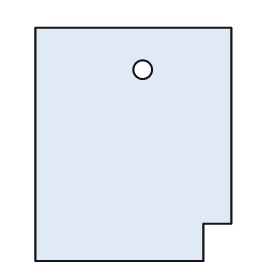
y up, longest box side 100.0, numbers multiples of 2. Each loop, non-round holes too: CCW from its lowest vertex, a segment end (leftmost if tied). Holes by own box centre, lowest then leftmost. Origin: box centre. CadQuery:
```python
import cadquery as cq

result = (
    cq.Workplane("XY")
    .moveTo(-42.0, -50.0)
    .lineTo(30.0, -50.0)
    .lineTo(30.0, -34.0)
    .lineTo(42.0, -34.0)
    .lineTo(42.0, 50.0)
    .lineTo(-42.0, 50.0)
    .close()
    .moveTo(4.0, 32.0)
    .circle(4.0)
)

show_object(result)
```